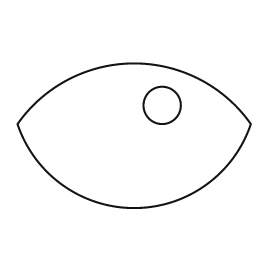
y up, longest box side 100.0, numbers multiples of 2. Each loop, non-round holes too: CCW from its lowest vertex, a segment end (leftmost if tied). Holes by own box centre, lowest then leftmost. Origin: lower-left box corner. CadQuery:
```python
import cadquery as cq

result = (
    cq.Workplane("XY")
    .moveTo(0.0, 36.0)
    .threePointArc((50.0, 0.0), (100.0, 36.0))
    .threePointArc((50.0, 62.0), (0.0, 36.0))
    .close()
    .moveTo(62.0, 44.0)
    .circle(8.0)
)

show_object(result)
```